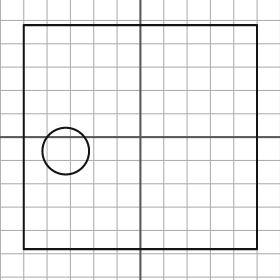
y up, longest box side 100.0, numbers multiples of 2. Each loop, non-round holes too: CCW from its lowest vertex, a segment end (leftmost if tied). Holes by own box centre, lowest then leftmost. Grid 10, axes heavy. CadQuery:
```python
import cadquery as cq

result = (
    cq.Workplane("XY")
    .moveTo(-50.0, -48.0)
    .lineTo(50.0, -48.0)
    .lineTo(50.0, 48.0)
    .lineTo(-50.0, 48.0)
    .close()
    .moveTo(-32.0, -6.0)
    .circle(10.0)
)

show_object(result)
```